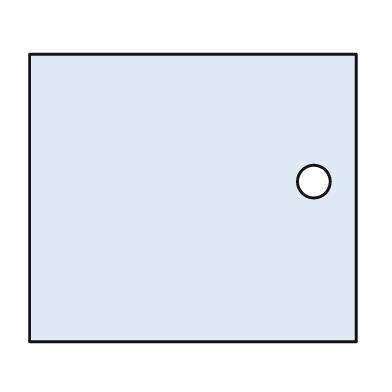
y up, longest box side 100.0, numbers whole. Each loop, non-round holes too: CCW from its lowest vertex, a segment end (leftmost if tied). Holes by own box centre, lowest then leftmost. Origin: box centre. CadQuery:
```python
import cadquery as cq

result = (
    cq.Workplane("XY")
    .moveTo(-50.0, -44.0)
    .lineTo(50.0, -44.0)
    .lineTo(50.0, 44.0)
    .lineTo(-50.0, 44.0)
    .close()
    .moveTo(37.0, 5.0)
    .circle(5.0)
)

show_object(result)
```